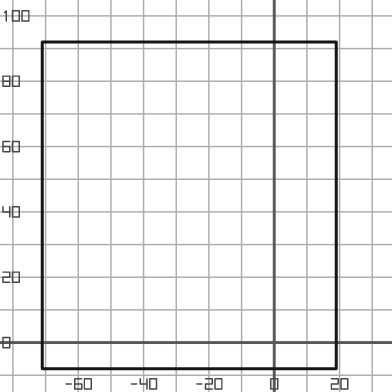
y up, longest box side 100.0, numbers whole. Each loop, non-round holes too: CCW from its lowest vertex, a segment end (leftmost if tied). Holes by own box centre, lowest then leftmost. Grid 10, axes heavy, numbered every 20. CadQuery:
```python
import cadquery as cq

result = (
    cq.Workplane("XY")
    .moveTo(-71.0, -8.0)
    .lineTo(19.0, -8.0)
    .lineTo(19.0, 92.0)
    .lineTo(-71.0, 92.0)
    .close()
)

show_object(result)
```